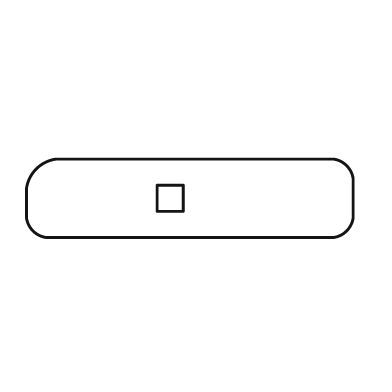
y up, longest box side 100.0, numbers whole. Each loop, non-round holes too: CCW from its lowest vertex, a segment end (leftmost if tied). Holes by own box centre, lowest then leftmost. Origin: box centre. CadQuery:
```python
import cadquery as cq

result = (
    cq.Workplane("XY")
    .moveTo(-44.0, -12.0)
    .lineTo(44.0, -12.0)
    .threePointArc((48.0, -10.0), (50.0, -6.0))
    .lineTo(50.0, 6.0)
    .threePointArc((48.0, 10.0), (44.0, 12.0))
    .lineTo(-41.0, 12.0)
    .threePointArc((-47.0, 9.0), (-50.0, 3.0))
    .lineTo(-50.0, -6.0)
    .threePointArc((-48.0, -10.0), (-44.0, -12.0))
    .close()
    .moveTo(-10.0, -4.0)
    .lineTo(-2.0, -4.0)
    .lineTo(-2.0, 4.0)
    .lineTo(-10.0, 4.0)
    .close()
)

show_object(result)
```